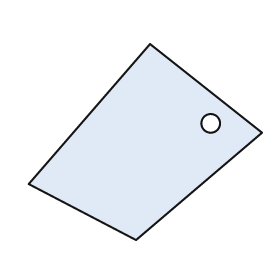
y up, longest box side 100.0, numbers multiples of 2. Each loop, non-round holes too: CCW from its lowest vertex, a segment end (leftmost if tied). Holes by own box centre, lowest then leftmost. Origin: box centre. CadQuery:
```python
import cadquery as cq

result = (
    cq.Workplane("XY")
    .moveTo(-4.0, -42.0)
    .lineTo(50.0, 4.0)
    .lineTo(2.0, 42.0)
    .lineTo(-50.0, -18.0)
    .close()
    .moveTo(28.0, 8.0)
    .circle(4.0)
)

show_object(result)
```